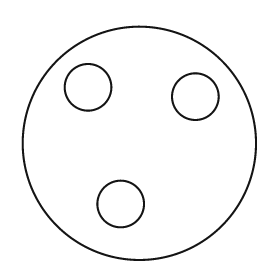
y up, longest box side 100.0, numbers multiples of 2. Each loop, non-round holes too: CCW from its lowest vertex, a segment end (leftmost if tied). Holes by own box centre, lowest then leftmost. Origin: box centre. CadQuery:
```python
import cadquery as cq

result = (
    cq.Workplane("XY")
    .moveTo(0.0, 0.0)
    .circle(50.0)
    .moveTo(-8.0, -26.0)
    .circle(10.0)
    .moveTo(24.0, 20.0)
    .circle(10.0)
    .moveTo(-22.0, 24.0)
    .circle(10.0)
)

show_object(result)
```